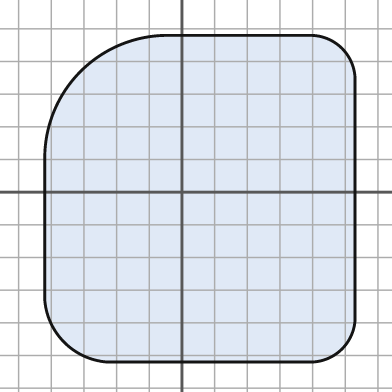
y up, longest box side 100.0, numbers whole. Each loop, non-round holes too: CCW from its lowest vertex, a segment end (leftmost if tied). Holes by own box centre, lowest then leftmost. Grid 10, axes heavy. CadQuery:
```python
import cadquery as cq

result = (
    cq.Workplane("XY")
    .moveTo(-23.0, -52.0)
    .lineTo(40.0, -52.0)
    .threePointArc((49.0, -48.0), (53.0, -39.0))
    .lineTo(53.0, 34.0)
    .threePointArc((49.0, 44.0), (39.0, 48.0))
    .lineTo(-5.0, 48.0)
    .threePointArc((-31.0, 37.0), (-42.0, 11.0))
    .lineTo(-42.0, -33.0)
    .threePointArc((-36.0, -46.0), (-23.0, -52.0))
    .close()
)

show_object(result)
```